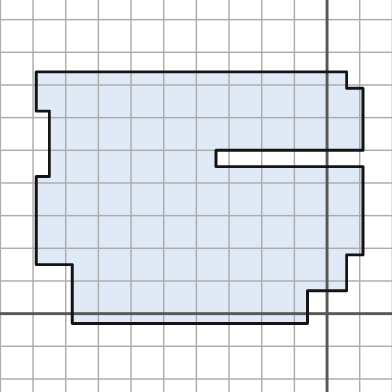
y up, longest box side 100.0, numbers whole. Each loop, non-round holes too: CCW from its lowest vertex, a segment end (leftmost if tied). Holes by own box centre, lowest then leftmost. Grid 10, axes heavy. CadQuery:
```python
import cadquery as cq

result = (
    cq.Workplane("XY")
    .moveTo(-78.0, -3.0)
    .lineTo(-6.0, -3.0)
    .lineTo(-6.0, 7.0)
    .lineTo(6.0, 7.0)
    .lineTo(6.0, 18.0)
    .lineTo(11.0, 18.0)
    .lineTo(11.0, 45.0)
    .lineTo(-34.0, 45.0)
    .lineTo(-34.0, 50.0)
    .lineTo(11.0, 50.0)
    .lineTo(11.0, 69.0)
    .lineTo(6.0, 69.0)
    .lineTo(6.0, 74.0)
    .lineTo(-89.0, 74.0)
    .lineTo(-89.0, 62.0)
    .lineTo(-85.0, 62.0)
    .lineTo(-85.0, 42.0)
    .lineTo(-89.0, 42.0)
    .lineTo(-89.0, 15.0)
    .lineTo(-78.0, 15.0)
    .close()
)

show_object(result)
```